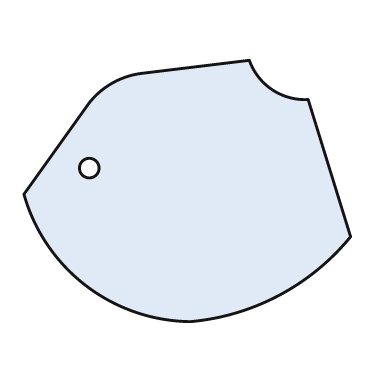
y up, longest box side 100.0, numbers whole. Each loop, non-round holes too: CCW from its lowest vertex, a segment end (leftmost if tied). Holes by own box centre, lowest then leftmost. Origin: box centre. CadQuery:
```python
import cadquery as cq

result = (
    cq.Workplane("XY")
    .moveTo(1.0, -40.0)
    .threePointArc((28.0, -32.0), (50.0, -14.0))
    .lineTo(37.0, 28.0)
    .threePointArc((26.0, 31.0), (19.0, 40.0))
    .lineTo(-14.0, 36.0)
    .threePointArc((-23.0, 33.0), (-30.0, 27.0))
    .lineTo(-50.0, -1.0)
    .threePointArc((-31.0, -29.0), (1.0, -40.0))
    .close()
    .moveTo(-30.0, 7.0)
    .circle(3.0)
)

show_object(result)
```